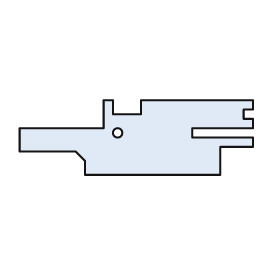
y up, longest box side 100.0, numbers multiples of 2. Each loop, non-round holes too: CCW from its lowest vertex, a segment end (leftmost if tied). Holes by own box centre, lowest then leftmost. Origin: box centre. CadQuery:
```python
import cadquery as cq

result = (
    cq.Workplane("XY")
    .moveTo(-22.0, -16.0)
    .lineTo(36.0, -16.0)
    .lineTo(36.0, -4.0)
    .lineTo(50.0, -4.0)
    .lineTo(50.0, 0.0)
    .lineTo(24.0, 0.0)
    .lineTo(24.0, 4.0)
    .lineTo(50.0, 4.0)
    .lineTo(50.0, 8.0)
    .lineTo(46.0, 8.0)
    .lineTo(46.0, 12.0)
    .lineTo(50.0, 12.0)
    .lineTo(50.0, 16.0)
    .lineTo(2.0, 16.0)
    .lineTo(2.0, 10.0)
    .lineTo(-10.0, 10.0)
    .lineTo(-10.0, 16.0)
    .lineTo(-14.0, 16.0)
    .lineTo(-14.0, 4.0)
    .lineTo(-50.0, 4.0)
    .lineTo(-50.0, -6.0)
    .lineTo(-26.0, -6.0)
    .lineTo(-22.0, -10.0)
    .close()
    .moveTo(-8.0, 2.0)
    .circle(2.0)
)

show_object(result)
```